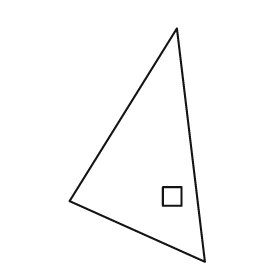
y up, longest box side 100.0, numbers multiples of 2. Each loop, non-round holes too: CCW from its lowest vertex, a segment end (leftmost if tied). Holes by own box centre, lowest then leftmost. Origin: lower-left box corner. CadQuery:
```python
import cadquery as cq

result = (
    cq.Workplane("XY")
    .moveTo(58.0, 0.0)
    .lineTo(46.0, 100.0)
    .lineTo(0.0, 26.0)
    .close()
    .moveTo(40.0, 24.0)
    .lineTo(48.0, 24.0)
    .lineTo(48.0, 32.0)
    .lineTo(40.0, 32.0)
    .close()
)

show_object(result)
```